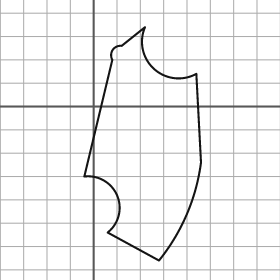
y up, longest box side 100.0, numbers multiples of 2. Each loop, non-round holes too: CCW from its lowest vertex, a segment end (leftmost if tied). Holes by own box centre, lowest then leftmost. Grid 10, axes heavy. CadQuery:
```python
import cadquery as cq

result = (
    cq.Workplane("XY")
    .moveTo(28.0, -66.0)
    .threePointArc((40.0, -46.0), (46.0, -24.0))
    .lineTo(44.0, 14.0)
    .threePointArc((26.0, 16.0), (22.0, 34.0))
    .lineTo(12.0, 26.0)
    .threePointArc((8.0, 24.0), (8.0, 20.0))
    .lineTo(-4.0, -30.0)
    .threePointArc((10.0, -38.0), (6.0, -54.0))
    .close()
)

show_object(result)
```